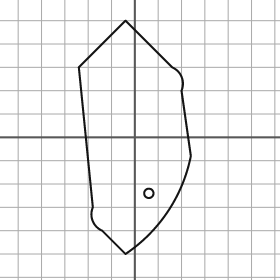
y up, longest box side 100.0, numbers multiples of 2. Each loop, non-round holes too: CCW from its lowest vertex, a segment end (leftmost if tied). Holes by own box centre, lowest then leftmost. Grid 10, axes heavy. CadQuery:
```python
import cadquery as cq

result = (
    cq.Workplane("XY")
    .moveTo(-4.0, -50.0)
    .threePointArc((14.0, -32.0), (24.0, -8.0))
    .lineTo(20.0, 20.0)
    .threePointArc((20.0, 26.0), (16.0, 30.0))
    .lineTo(-4.0, 50.0)
    .lineTo(-24.0, 30.0)
    .lineTo(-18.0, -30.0)
    .threePointArc((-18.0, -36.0), (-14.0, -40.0))
    .close()
    .moveTo(6.0, -24.0)
    .circle(2.0)
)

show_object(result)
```